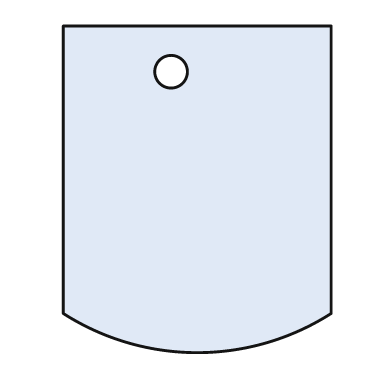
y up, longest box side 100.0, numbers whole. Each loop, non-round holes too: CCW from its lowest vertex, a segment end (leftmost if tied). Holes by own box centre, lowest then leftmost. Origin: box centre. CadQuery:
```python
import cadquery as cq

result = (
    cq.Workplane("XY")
    .moveTo(-41.0, -38.0)
    .threePointArc((0.0, -50.0), (41.0, -38.0))
    .lineTo(41.0, 50.0)
    .lineTo(-41.0, 50.0)
    .close()
    .moveTo(-8.0, 36.0)
    .circle(5.0)
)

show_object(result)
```